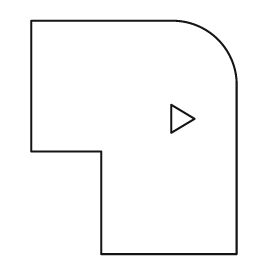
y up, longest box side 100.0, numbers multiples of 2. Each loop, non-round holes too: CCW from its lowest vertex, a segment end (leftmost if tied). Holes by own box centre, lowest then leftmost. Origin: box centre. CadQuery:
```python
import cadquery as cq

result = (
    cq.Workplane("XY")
    .moveTo(-14.0, -50.0)
    .lineTo(44.0, -50.0)
    .lineTo(44.0, 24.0)
    .threePointArc((36.0, 42.0), (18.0, 50.0))
    .lineTo(-44.0, 50.0)
    .lineTo(-44.0, -6.0)
    .lineTo(-14.0, -6.0)
    .close()
    .moveTo(16.0, 2.0)
    .lineTo(26.0, 8.0)
    .lineTo(16.0, 14.0)
    .close()
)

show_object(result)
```